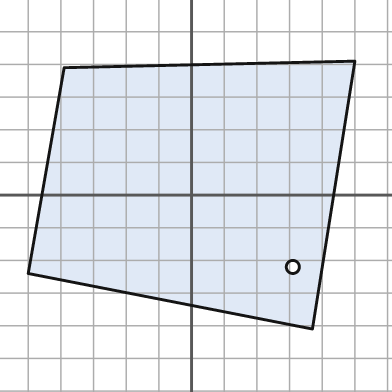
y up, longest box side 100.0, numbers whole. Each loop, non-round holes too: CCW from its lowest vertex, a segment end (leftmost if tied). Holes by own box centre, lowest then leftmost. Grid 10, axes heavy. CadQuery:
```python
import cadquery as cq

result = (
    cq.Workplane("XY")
    .moveTo(37.0, -41.0)
    .lineTo(50.0, 41.0)
    .lineTo(-39.0, 39.0)
    .lineTo(-50.0, -24.0)
    .close()
    .moveTo(31.0, -22.0)
    .circle(2.0)
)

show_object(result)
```